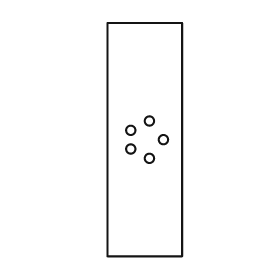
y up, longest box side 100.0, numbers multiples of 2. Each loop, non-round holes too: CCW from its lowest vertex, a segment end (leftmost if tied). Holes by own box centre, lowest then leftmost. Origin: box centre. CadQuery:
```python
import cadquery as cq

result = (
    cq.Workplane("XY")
    .moveTo(-16.0, -50.0)
    .lineTo(16.0, -50.0)
    .lineTo(16.0, 50.0)
    .lineTo(-16.0, 50.0)
    .close()
    .moveTo(2.0, -8.0)
    .circle(2.0)
    .moveTo(-6.0, -4.0)
    .circle(2.0)
    .moveTo(8.0, 0.0)
    .circle(2.0)
    .moveTo(-6.0, 4.0)
    .circle(2.0)
    .moveTo(2.0, 8.0)
    .circle(2.0)
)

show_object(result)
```